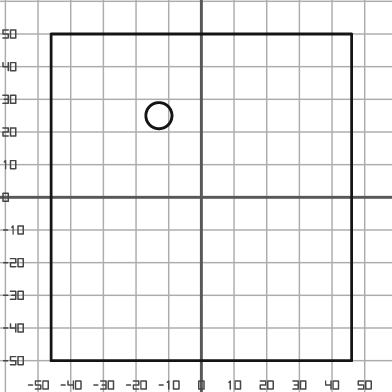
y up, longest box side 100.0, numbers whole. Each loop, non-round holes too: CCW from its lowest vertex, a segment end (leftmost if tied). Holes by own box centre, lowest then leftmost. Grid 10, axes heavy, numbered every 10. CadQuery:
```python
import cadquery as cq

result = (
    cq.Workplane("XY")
    .moveTo(-46.0, -50.0)
    .lineTo(46.0, -50.0)
    .lineTo(46.0, 50.0)
    .lineTo(-46.0, 50.0)
    .close()
    .moveTo(-13.0, 25.0)
    .circle(4.0)
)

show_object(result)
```